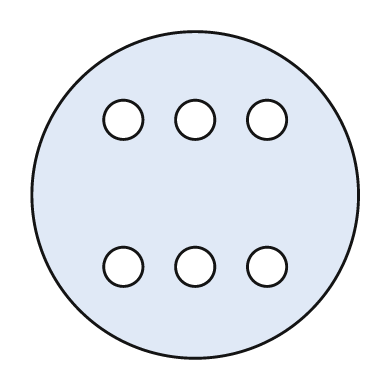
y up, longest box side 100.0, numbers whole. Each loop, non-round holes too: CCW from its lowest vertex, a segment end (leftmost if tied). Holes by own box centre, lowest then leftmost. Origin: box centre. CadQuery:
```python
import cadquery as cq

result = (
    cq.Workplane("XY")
    .moveTo(0.0, 0.0)
    .circle(50.0)
    .moveTo(-22.0, -22.0)
    .circle(6.0)
    .moveTo(0.0, -22.0)
    .circle(6.0)
    .moveTo(22.0, -22.0)
    .circle(6.0)
    .moveTo(-22.0, 23.0)
    .circle(6.0)
    .moveTo(0.0, 23.0)
    .circle(6.0)
    .moveTo(22.0, 23.0)
    .circle(6.0)
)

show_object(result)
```